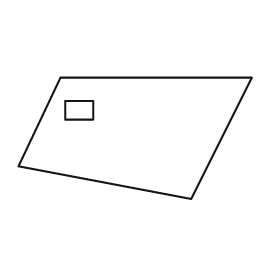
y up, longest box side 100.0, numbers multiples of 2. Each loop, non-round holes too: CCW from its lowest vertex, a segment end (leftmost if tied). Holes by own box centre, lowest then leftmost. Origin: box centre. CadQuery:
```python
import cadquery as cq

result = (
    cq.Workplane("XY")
    .moveTo(24.0, -26.0)
    .lineTo(50.0, 26.0)
    .lineTo(-32.0, 26.0)
    .lineTo(-50.0, -12.0)
    .close()
    .moveTo(-30.0, 8.0)
    .lineTo(-18.0, 8.0)
    .lineTo(-18.0, 16.0)
    .lineTo(-30.0, 16.0)
    .close()
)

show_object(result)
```